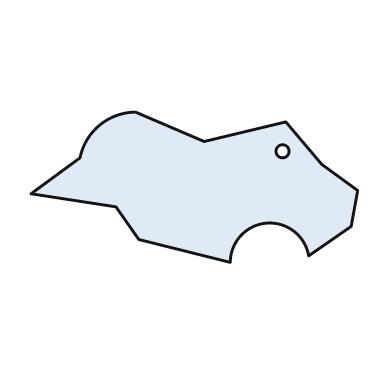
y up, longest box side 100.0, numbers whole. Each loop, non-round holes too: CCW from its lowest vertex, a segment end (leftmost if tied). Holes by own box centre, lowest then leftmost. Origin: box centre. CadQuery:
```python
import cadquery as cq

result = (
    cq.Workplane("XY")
    .moveTo(11.0, -23.0)
    .threePointArc((22.0, -11.0), (35.0, -21.0))
    .lineTo(48.0, -12.0)
    .lineTo(50.0, -1.0)
    .lineTo(39.0, 7.0)
    .lineTo(28.0, 20.0)
    .lineTo(3.0, 14.0)
    .lineTo(-18.0, 23.0)
    .threePointArc((-29.0, 19.0), (-35.0, 9.0))
    .lineTo(-50.0, -2.0)
    .lineTo(-24.0, -6.0)
    .lineTo(-17.0, -16.0)
    .close()
    .moveTo(27.0, 11.0)
    .circle(2.0)
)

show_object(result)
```